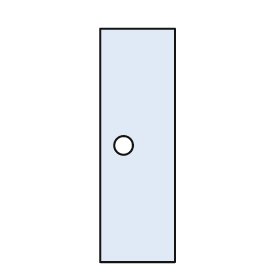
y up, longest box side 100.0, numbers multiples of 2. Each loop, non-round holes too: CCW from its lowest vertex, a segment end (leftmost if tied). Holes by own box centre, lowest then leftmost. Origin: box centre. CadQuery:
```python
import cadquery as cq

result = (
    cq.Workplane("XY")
    .moveTo(-16.0, -50.0)
    .lineTo(16.0, -50.0)
    .lineTo(16.0, 50.0)
    .lineTo(-16.0, 50.0)
    .close()
    .moveTo(-6.0, 0.0)
    .circle(4.0)
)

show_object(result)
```